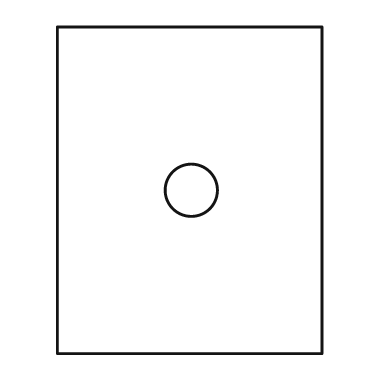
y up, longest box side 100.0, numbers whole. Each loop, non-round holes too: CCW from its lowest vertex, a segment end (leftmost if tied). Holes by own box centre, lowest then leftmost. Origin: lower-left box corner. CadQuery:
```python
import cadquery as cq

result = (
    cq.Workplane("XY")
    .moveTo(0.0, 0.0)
    .lineTo(81.0, 0.0)
    .lineTo(81.0, 100.0)
    .lineTo(0.0, 100.0)
    .close()
    .moveTo(41.0, 50.0)
    .circle(8.0)
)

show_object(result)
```